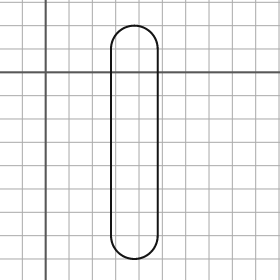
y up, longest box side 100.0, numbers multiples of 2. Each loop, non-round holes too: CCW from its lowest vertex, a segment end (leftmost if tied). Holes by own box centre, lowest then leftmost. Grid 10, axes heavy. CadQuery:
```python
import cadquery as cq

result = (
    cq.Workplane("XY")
    .moveTo(28.0, -70.0)
    .threePointArc((38.0, -80.0), (48.0, -70.0))
    .lineTo(48.0, 10.0)
    .threePointArc((38.0, 20.0), (28.0, 10.0))
    .close()
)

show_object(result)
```